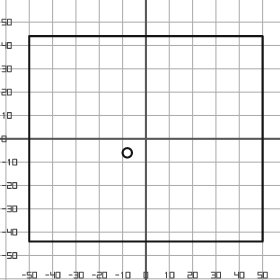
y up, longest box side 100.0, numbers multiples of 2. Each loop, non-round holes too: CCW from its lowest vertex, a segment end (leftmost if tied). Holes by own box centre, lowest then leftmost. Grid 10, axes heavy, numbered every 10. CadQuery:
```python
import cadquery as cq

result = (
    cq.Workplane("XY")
    .moveTo(-50.0, -44.0)
    .lineTo(50.0, -44.0)
    .lineTo(50.0, 44.0)
    .lineTo(-50.0, 44.0)
    .close()
    .moveTo(-8.0, -6.0)
    .circle(2.0)
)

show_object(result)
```